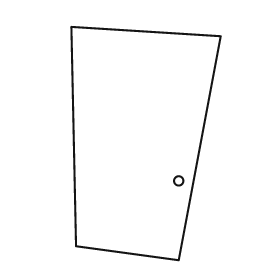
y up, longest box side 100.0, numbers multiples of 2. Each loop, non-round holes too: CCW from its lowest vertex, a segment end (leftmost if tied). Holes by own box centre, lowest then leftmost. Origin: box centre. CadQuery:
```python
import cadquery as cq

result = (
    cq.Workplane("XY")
    .moveTo(14.0, -50.0)
    .lineTo(32.0, 46.0)
    .lineTo(-32.0, 50.0)
    .lineTo(-30.0, -44.0)
    .close()
    .moveTo(14.0, -16.0)
    .circle(2.0)
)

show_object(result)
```